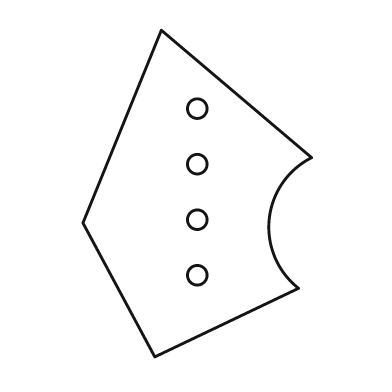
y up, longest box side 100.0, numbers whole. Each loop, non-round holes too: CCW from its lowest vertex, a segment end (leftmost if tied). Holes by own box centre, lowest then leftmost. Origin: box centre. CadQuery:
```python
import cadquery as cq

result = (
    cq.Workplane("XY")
    .moveTo(-13.0, -50.0)
    .lineTo(31.0, -29.0)
    .threePointArc((22.0, -8.0), (35.0, 11.0))
    .lineTo(-11.0, 50.0)
    .lineTo(-35.0, -9.0)
    .close()
    .moveTo(0.0, -25.0)
    .circle(3.0)
    .moveTo(0.0, -8.0)
    .circle(3.0)
    .moveTo(0.0, 9.0)
    .circle(3.0)
    .moveTo(0.0, 26.0)
    .circle(3.0)
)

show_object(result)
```